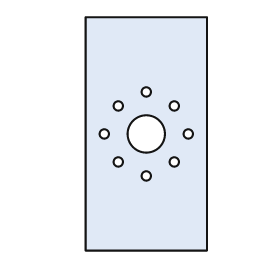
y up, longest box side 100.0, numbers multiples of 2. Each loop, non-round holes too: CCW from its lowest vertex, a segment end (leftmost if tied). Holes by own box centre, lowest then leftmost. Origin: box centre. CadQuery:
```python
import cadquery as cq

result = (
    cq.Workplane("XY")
    .moveTo(-26.0, -50.0)
    .lineTo(26.0, -50.0)
    .lineTo(26.0, 50.0)
    .lineTo(-26.0, 50.0)
    .close()
    .moveTo(0.0, -18.0)
    .circle(2.0)
    .moveTo(-12.0, -12.0)
    .circle(2.0)
    .moveTo(12.0, -12.0)
    .circle(2.0)
    .moveTo(-18.0, 0.0)
    .circle(2.0)
    .moveTo(0.0, 0.0)
    .circle(8.0)
    .moveTo(18.0, 0.0)
    .circle(2.0)
    .moveTo(-12.0, 12.0)
    .circle(2.0)
    .moveTo(12.0, 12.0)
    .circle(2.0)
    .moveTo(0.0, 18.0)
    .circle(2.0)
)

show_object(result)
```